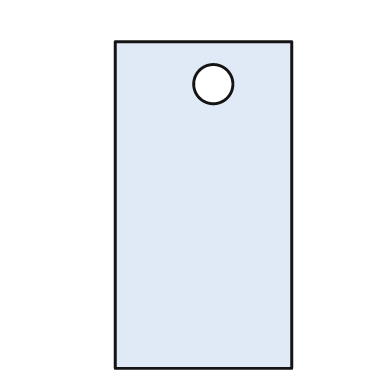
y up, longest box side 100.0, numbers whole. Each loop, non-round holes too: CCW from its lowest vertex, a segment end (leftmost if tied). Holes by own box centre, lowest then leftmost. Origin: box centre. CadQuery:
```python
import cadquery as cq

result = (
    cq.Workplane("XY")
    .moveTo(-27.0, -50.0)
    .lineTo(27.0, -50.0)
    .lineTo(27.0, 50.0)
    .lineTo(-27.0, 50.0)
    .close()
    .moveTo(3.0, 37.0)
    .circle(6.0)
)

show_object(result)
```